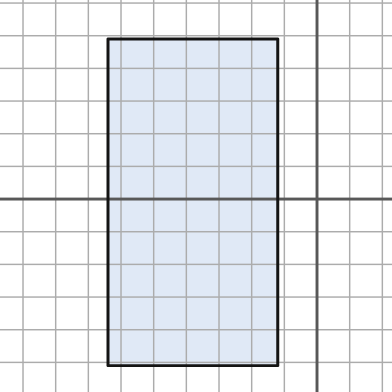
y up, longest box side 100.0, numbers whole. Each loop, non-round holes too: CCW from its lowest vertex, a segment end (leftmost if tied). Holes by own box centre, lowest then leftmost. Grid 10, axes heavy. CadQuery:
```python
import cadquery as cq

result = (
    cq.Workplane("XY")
    .moveTo(-64.0, -51.0)
    .lineTo(-12.0, -51.0)
    .lineTo(-12.0, 49.0)
    .lineTo(-64.0, 49.0)
    .close()
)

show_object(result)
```